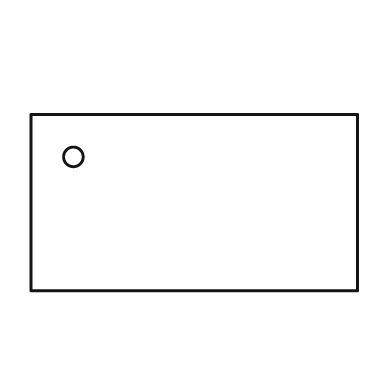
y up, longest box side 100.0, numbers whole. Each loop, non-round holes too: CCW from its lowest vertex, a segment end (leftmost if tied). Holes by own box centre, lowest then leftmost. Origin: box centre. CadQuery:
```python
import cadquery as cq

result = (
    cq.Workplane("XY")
    .moveTo(-50.0, -27.0)
    .lineTo(50.0, -27.0)
    .lineTo(50.0, 27.0)
    .lineTo(-50.0, 27.0)
    .close()
    .moveTo(-37.0, 14.0)
    .circle(3.0)
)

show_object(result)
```